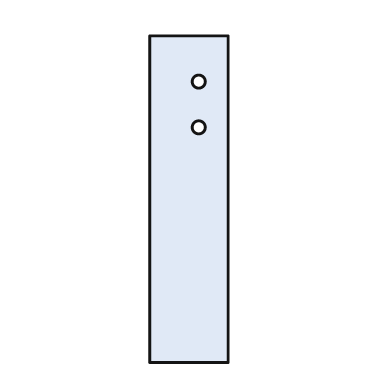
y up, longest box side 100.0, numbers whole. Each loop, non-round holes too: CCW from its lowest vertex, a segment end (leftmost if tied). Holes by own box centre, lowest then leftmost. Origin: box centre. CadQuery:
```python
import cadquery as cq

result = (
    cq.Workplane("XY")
    .moveTo(-12.0, -50.0)
    .lineTo(12.0, -50.0)
    .lineTo(12.0, 50.0)
    .lineTo(-12.0, 50.0)
    .close()
    .moveTo(3.0, 22.0)
    .circle(2.0)
    .moveTo(3.0, 36.0)
    .circle(2.0)
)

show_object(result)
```